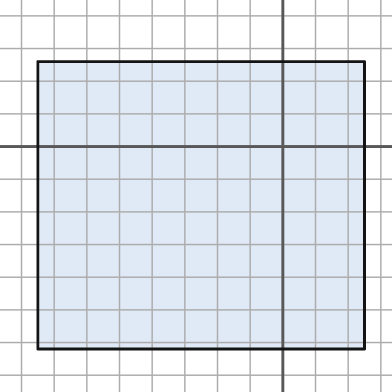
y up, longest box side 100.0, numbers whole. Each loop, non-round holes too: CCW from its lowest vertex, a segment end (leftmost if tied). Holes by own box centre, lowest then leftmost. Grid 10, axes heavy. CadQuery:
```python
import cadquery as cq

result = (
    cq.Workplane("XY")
    .moveTo(-75.0, -62.0)
    .lineTo(25.0, -62.0)
    .lineTo(25.0, 26.0)
    .lineTo(-75.0, 26.0)
    .close()
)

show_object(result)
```